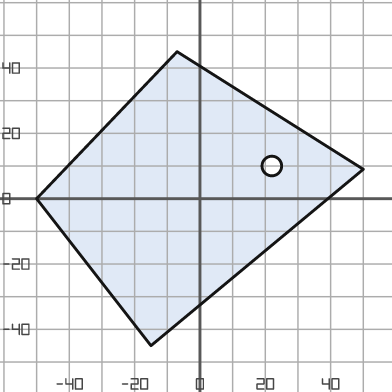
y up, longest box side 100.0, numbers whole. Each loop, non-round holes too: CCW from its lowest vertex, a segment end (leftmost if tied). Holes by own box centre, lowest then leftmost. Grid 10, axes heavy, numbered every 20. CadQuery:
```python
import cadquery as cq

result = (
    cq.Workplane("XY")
    .moveTo(-15.0, -45.0)
    .lineTo(50.0, 9.0)
    .lineTo(-7.0, 45.0)
    .lineTo(-50.0, 0.0)
    .close()
    .moveTo(22.0, 10.0)
    .circle(3.0)
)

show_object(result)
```